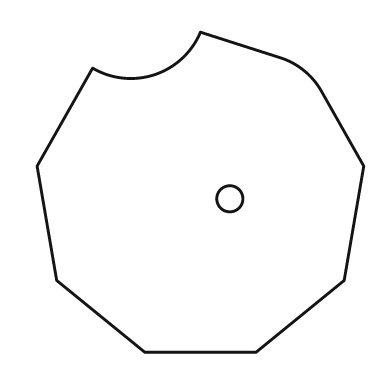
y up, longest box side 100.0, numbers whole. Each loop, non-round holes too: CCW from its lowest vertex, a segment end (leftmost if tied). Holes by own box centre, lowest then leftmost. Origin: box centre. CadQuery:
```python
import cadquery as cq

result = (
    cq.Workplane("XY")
    .moveTo(-17.0, -49.0)
    .lineTo(17.0, -49.0)
    .lineTo(44.0, -27.0)
    .lineTo(50.0, 8.0)
    .lineTo(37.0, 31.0)
    .threePointArc((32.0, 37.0), (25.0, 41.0))
    .lineTo(0.0, 49.0)
    .threePointArc((-14.0, 36.0), (-33.0, 38.0))
    .lineTo(-50.0, 8.0)
    .lineTo(-44.0, -27.0)
    .close()
    .moveTo(9.0, -2.0)
    .circle(4.0)
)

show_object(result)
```